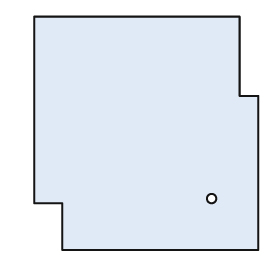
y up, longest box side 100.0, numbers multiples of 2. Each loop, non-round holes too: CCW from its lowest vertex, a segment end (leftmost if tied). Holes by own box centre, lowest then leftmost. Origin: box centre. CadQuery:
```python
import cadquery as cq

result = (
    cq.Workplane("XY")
    .moveTo(-36.0, -50.0)
    .lineTo(48.0, -50.0)
    .lineTo(48.0, 16.0)
    .lineTo(40.0, 16.0)
    .lineTo(40.0, 50.0)
    .lineTo(-48.0, 50.0)
    .lineTo(-48.0, -30.0)
    .lineTo(-36.0, -30.0)
    .close()
    .moveTo(28.0, -28.0)
    .circle(2.0)
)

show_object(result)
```